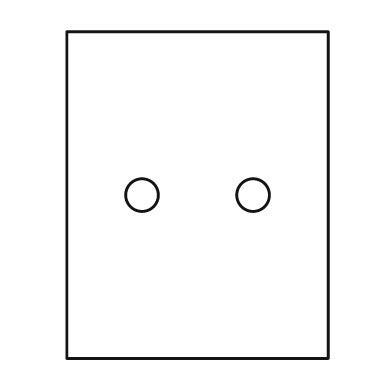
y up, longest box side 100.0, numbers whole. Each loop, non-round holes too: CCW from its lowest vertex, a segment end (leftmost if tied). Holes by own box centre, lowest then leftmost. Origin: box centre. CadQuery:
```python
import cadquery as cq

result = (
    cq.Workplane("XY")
    .moveTo(-40.0, -50.0)
    .lineTo(40.0, -50.0)
    .lineTo(40.0, 50.0)
    .lineTo(-40.0, 50.0)
    .close()
    .moveTo(-17.0, 0.0)
    .circle(5.0)
    .moveTo(17.0, 0.0)
    .circle(5.0)
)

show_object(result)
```